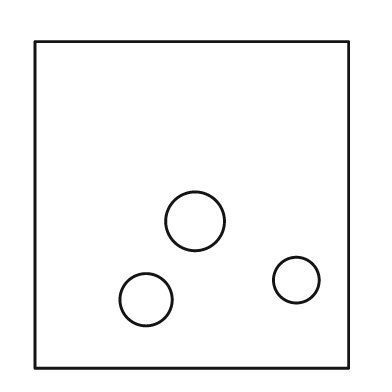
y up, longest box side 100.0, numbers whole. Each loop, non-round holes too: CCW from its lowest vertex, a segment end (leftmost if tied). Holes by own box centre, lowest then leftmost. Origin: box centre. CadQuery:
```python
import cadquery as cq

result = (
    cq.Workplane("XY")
    .moveTo(-48.0, -50.0)
    .lineTo(48.0, -50.0)
    .lineTo(48.0, 50.0)
    .lineTo(-48.0, 50.0)
    .close()
    .moveTo(-14.0, -29.0)
    .circle(8.0)
    .moveTo(32.0, -23.0)
    .circle(7.0)
    .moveTo(1.0, -5.0)
    .circle(9.0)
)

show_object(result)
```